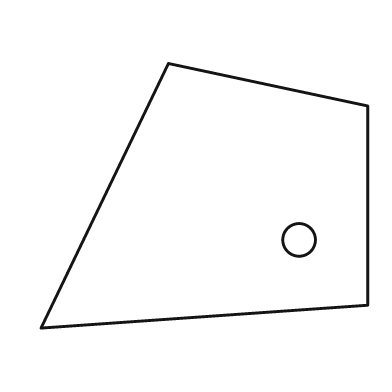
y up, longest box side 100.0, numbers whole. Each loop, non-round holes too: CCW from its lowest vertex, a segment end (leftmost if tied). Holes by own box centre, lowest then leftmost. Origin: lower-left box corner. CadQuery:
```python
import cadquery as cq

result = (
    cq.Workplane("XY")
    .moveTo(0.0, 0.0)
    .lineTo(100.0, 7.0)
    .lineTo(100.0, 68.0)
    .lineTo(39.0, 81.0)
    .close()
    .moveTo(79.0, 27.0)
    .circle(5.0)
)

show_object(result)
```